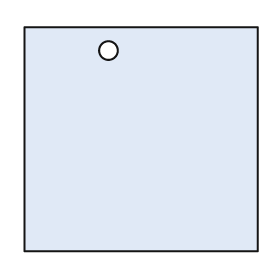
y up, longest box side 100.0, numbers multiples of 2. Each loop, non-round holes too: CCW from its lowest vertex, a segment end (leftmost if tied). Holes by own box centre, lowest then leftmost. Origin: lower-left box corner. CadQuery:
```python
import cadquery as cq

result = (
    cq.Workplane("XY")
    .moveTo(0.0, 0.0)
    .lineTo(100.0, 0.0)
    .lineTo(100.0, 96.0)
    .lineTo(0.0, 96.0)
    .close()
    .moveTo(36.0, 86.0)
    .circle(4.0)
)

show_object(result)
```